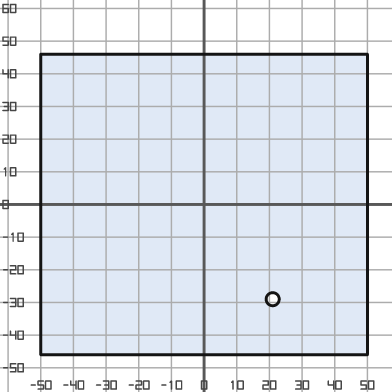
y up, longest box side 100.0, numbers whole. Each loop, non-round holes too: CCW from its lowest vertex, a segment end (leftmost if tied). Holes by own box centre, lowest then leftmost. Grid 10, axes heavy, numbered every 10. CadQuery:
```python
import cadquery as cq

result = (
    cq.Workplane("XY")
    .moveTo(-50.0, -46.0)
    .lineTo(50.0, -46.0)
    .lineTo(50.0, 46.0)
    .lineTo(-50.0, 46.0)
    .close()
    .moveTo(21.0, -29.0)
    .circle(2.0)
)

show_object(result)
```